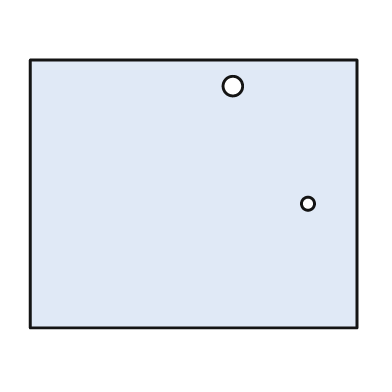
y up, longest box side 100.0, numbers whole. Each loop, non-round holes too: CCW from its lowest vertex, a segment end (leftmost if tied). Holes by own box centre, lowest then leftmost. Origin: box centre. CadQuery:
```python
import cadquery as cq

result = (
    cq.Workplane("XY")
    .moveTo(-50.0, -41.0)
    .lineTo(50.0, -41.0)
    .lineTo(50.0, 41.0)
    .lineTo(-50.0, 41.0)
    .close()
    .moveTo(35.0, -3.0)
    .circle(2.0)
    .moveTo(12.0, 33.0)
    .circle(3.0)
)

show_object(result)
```